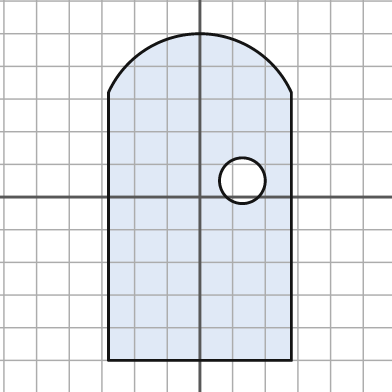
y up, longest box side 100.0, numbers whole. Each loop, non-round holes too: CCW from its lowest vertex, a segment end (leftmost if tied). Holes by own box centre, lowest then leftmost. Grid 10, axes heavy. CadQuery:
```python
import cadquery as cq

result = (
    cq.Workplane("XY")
    .moveTo(-28.0, -50.0)
    .lineTo(28.0, -50.0)
    .lineTo(28.0, 32.0)
    .threePointArc((0.0, 50.0), (-28.0, 32.0))
    .close()
    .moveTo(13.0, 5.0)
    .circle(7.0)
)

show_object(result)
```